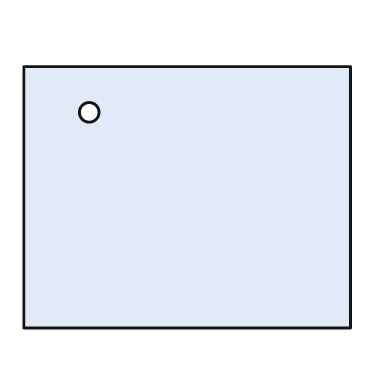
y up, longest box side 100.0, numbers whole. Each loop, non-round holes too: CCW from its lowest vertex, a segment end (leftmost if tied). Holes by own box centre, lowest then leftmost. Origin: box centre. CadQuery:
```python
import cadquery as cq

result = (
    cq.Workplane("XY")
    .moveTo(-50.0, -40.0)
    .lineTo(50.0, -40.0)
    .lineTo(50.0, 40.0)
    .lineTo(-50.0, 40.0)
    .close()
    .moveTo(-30.0, 26.0)
    .circle(3.0)
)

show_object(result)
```